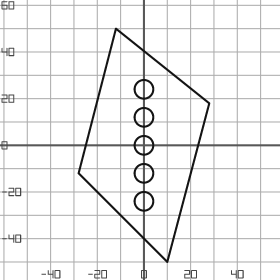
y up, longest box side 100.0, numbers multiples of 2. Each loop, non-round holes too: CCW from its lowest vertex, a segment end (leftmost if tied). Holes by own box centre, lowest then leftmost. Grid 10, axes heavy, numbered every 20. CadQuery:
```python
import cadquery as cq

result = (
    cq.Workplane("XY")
    .moveTo(10.0, -50.0)
    .lineTo(28.0, 18.0)
    .lineTo(-12.0, 50.0)
    .lineTo(-28.0, -12.0)
    .close()
    .moveTo(0.0, -24.0)
    .circle(4.0)
    .moveTo(0.0, -12.0)
    .circle(4.0)
    .moveTo(0.0, 0.0)
    .circle(4.0)
    .moveTo(0.0, 12.0)
    .circle(4.0)
    .moveTo(0.0, 24.0)
    .circle(4.0)
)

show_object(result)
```